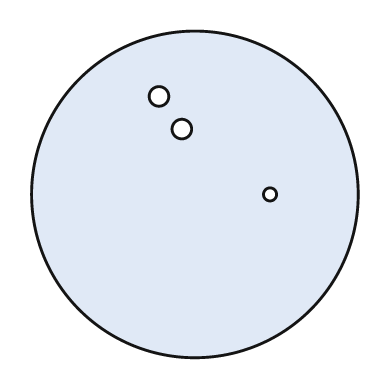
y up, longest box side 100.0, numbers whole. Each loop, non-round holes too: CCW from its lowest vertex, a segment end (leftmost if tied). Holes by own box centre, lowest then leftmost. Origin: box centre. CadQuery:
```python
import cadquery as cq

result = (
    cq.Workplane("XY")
    .moveTo(0.0, 0.0)
    .circle(50.0)
    .moveTo(23.0, 0.0)
    .circle(2.0)
    .moveTo(-4.0, 20.0)
    .circle(3.0)
    .moveTo(-11.0, 30.0)
    .circle(3.0)
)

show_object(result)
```